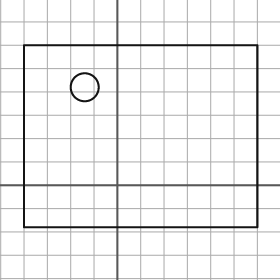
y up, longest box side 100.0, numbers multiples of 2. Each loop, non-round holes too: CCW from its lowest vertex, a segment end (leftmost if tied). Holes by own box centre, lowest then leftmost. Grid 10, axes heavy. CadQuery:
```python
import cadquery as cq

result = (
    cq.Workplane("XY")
    .moveTo(-40.0, -18.0)
    .lineTo(60.0, -18.0)
    .lineTo(60.0, 60.0)
    .lineTo(-40.0, 60.0)
    .close()
    .moveTo(-14.0, 42.0)
    .circle(6.0)
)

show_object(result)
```